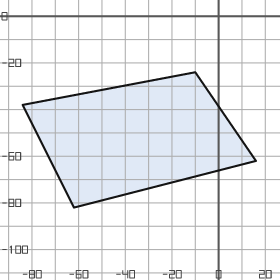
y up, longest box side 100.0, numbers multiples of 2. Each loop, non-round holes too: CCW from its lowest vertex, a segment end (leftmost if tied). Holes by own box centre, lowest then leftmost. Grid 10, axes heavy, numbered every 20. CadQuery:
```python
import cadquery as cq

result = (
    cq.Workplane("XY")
    .moveTo(-62.0, -82.0)
    .lineTo(16.0, -62.0)
    .lineTo(-10.0, -24.0)
    .lineTo(-84.0, -38.0)
    .close()
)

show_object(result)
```